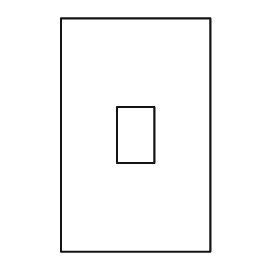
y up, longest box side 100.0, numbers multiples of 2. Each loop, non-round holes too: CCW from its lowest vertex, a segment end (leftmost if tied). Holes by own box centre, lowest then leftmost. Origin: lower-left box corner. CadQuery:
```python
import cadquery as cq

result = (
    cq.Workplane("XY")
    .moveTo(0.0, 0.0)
    .lineTo(64.0, 0.0)
    .lineTo(64.0, 100.0)
    .lineTo(0.0, 100.0)
    .close()
    .moveTo(24.0, 38.0)
    .lineTo(40.0, 38.0)
    .lineTo(40.0, 62.0)
    .lineTo(24.0, 62.0)
    .close()
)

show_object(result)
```